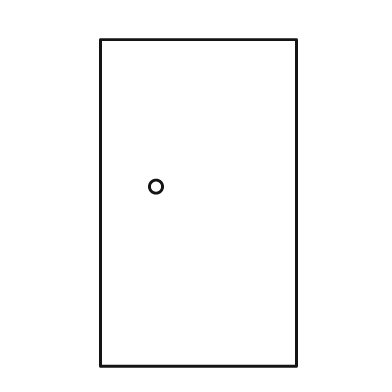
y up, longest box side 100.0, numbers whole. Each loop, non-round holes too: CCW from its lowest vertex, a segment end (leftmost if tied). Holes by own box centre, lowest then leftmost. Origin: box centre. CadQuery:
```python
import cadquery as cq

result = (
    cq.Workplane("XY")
    .moveTo(-30.0, -50.0)
    .lineTo(30.0, -50.0)
    .lineTo(30.0, 50.0)
    .lineTo(-30.0, 50.0)
    .close()
    .moveTo(-13.0, 5.0)
    .circle(2.0)
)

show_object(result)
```